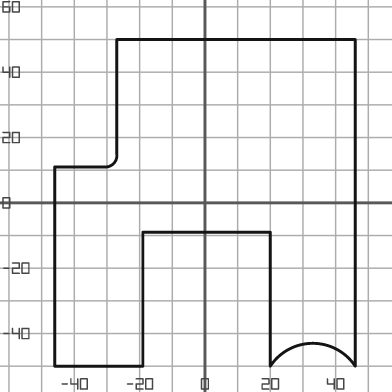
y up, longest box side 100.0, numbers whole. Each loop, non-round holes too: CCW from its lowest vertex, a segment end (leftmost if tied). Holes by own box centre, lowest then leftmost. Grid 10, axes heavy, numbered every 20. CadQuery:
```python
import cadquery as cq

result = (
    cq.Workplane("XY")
    .moveTo(-46.0, -50.0)
    .lineTo(-19.0, -50.0)
    .lineTo(-19.0, -9.0)
    .lineTo(20.0, -9.0)
    .lineTo(20.0, -50.0)
    .threePointArc((33.0, -43.0), (46.0, -50.0))
    .lineTo(46.0, 50.0)
    .lineTo(-27.0, 50.0)
    .lineTo(-27.0, 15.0)
    .threePointArc((-28.0, 12.0), (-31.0, 11.0))
    .lineTo(-46.0, 11.0)
    .close()
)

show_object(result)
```